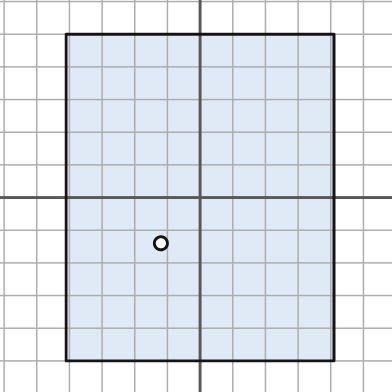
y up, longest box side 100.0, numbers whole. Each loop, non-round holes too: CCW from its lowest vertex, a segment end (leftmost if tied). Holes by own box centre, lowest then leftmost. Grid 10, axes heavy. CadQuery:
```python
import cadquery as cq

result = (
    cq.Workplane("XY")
    .moveTo(-41.0, -50.0)
    .lineTo(41.0, -50.0)
    .lineTo(41.0, 50.0)
    .lineTo(-41.0, 50.0)
    .close()
    .moveTo(-12.0, -14.0)
    .circle(2.0)
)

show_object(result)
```